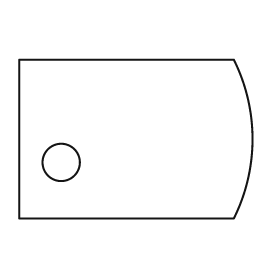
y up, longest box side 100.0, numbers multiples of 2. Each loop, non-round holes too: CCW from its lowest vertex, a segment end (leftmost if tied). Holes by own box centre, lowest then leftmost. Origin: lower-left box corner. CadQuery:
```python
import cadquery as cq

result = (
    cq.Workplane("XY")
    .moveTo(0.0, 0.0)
    .lineTo(92.0, 0.0)
    .threePointArc((100.0, 34.0), (92.0, 68.0))
    .lineTo(0.0, 68.0)
    .close()
    .moveTo(18.0, 24.0)
    .circle(8.0)
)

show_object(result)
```